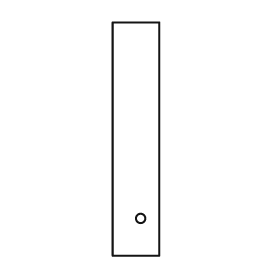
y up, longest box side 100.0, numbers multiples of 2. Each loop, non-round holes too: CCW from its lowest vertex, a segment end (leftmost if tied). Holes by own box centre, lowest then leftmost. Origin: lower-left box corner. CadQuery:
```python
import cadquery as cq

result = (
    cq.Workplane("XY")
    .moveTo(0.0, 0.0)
    .lineTo(20.0, 0.0)
    .lineTo(20.0, 100.0)
    .lineTo(0.0, 100.0)
    .close()
    .moveTo(12.0, 16.0)
    .circle(2.0)
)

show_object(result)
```